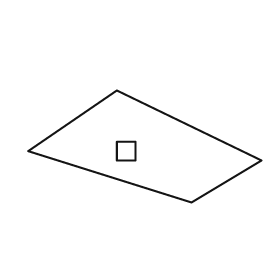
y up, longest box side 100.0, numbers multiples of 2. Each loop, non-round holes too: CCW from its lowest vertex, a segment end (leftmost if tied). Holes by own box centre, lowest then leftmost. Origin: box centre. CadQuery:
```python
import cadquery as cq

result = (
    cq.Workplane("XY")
    .moveTo(20.0, -24.0)
    .lineTo(50.0, -6.0)
    .lineTo(-12.0, 24.0)
    .lineTo(-50.0, -2.0)
    .close()
    .moveTo(-12.0, -6.0)
    .lineTo(-4.0, -6.0)
    .lineTo(-4.0, 2.0)
    .lineTo(-12.0, 2.0)
    .close()
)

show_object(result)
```